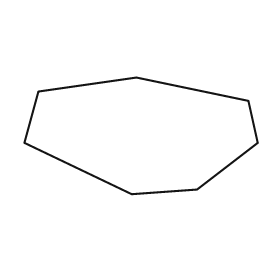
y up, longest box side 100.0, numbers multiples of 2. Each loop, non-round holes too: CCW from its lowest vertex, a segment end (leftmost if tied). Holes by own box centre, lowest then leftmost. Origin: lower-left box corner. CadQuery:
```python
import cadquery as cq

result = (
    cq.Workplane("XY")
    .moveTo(46.0, 0.0)
    .lineTo(74.0, 2.0)
    .lineTo(100.0, 22.0)
    .lineTo(96.0, 40.0)
    .lineTo(48.0, 50.0)
    .lineTo(6.0, 44.0)
    .lineTo(0.0, 22.0)
    .close()
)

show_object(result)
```